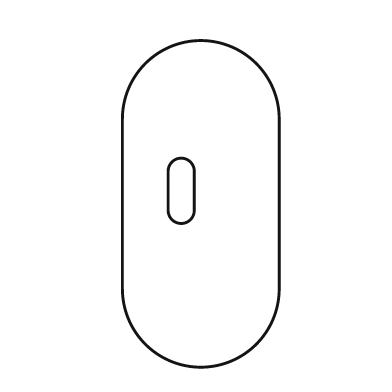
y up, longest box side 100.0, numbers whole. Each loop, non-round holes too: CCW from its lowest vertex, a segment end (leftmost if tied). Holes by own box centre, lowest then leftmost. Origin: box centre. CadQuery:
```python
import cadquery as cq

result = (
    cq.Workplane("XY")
    .moveTo(-24.0, -26.0)
    .threePointArc((0.0, -50.0), (24.0, -26.0))
    .lineTo(24.0, 26.0)
    .threePointArc((0.0, 50.0), (-24.0, 26.0))
    .close()
    .moveTo(-10.0, -2.0)
    .threePointArc((-6.0, -6.0), (-2.0, -2.0))
    .lineTo(-2.0, 10.0)
    .threePointArc((-6.0, 14.0), (-10.0, 10.0))
    .close()
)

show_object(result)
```